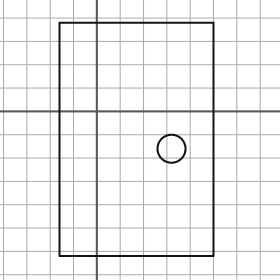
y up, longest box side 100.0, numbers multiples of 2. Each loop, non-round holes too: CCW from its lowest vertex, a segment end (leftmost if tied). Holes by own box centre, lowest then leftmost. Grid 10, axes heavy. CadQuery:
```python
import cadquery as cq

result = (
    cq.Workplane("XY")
    .moveTo(-16.0, -62.0)
    .lineTo(50.0, -62.0)
    .lineTo(50.0, 38.0)
    .lineTo(-16.0, 38.0)
    .close()
    .moveTo(32.0, -16.0)
    .circle(6.0)
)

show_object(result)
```